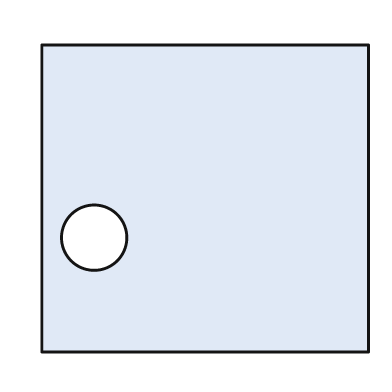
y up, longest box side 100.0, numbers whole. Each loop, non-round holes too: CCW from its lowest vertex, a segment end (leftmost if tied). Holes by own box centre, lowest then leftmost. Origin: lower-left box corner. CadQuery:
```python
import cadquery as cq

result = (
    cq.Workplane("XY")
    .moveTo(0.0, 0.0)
    .lineTo(100.0, 0.0)
    .lineTo(100.0, 94.0)
    .lineTo(0.0, 94.0)
    .close()
    .moveTo(16.0, 35.0)
    .circle(10.0)
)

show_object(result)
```